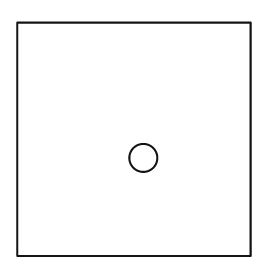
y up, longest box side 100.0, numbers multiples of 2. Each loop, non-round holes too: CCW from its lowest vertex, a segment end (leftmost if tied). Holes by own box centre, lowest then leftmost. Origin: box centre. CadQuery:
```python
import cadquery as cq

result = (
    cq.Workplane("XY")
    .moveTo(-50.0, -50.0)
    .lineTo(50.0, -50.0)
    .lineTo(50.0, 50.0)
    .lineTo(-50.0, 50.0)
    .close()
    .moveTo(4.0, -8.0)
    .circle(6.0)
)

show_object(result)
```